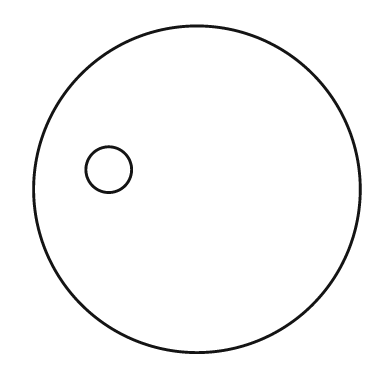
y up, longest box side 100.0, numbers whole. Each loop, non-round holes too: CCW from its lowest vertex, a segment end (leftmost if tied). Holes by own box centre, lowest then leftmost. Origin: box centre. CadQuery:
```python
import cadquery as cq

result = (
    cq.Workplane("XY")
    .moveTo(0.0, 0.0)
    .circle(50.0)
    .moveTo(-27.0, 6.0)
    .circle(7.0)
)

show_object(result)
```